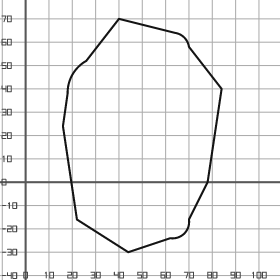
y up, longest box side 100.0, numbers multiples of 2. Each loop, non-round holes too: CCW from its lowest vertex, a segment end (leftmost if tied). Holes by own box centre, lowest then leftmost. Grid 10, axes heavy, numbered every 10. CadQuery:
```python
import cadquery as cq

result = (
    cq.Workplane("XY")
    .moveTo(44.0, -30.0)
    .lineTo(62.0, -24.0)
    .threePointArc((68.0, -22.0), (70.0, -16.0))
    .lineTo(78.0, 0.0)
    .lineTo(84.0, 40.0)
    .lineTo(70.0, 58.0)
    .threePointArc((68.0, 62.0), (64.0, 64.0))
    .lineTo(40.0, 70.0)
    .lineTo(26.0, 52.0)
    .threePointArc((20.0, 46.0), (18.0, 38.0))
    .lineTo(16.0, 24.0)
    .lineTo(22.0, -16.0)
    .close()
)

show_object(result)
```